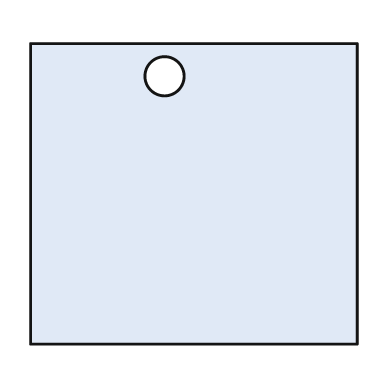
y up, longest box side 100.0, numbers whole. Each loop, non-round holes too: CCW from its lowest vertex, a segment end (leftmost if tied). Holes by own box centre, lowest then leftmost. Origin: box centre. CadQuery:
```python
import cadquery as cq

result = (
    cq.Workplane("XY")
    .moveTo(-50.0, -46.0)
    .lineTo(50.0, -46.0)
    .lineTo(50.0, 46.0)
    .lineTo(-50.0, 46.0)
    .close()
    .moveTo(-9.0, 36.0)
    .circle(6.0)
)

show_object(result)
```